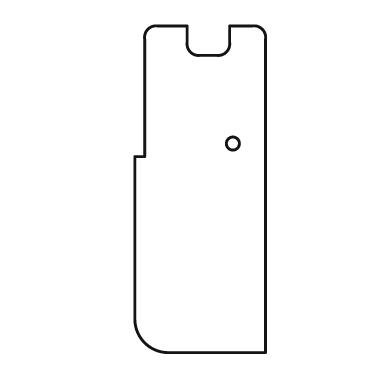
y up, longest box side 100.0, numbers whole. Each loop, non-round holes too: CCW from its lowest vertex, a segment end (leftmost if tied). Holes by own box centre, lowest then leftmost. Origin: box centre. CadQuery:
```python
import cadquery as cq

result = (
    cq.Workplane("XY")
    .moveTo(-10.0, -50.0)
    .lineTo(20.0, -50.0)
    .lineTo(20.0, 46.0)
    .threePointArc((19.0, 49.0), (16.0, 50.0))
    .lineTo(9.0, 50.0)
    .lineTo(9.0, 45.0)
    .threePointArc((8.0, 42.0), (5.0, 41.0))
    .lineTo(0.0, 41.0)
    .threePointArc((-3.0, 42.0), (-4.0, 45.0))
    .lineTo(-4.0, 50.0)
    .lineTo(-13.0, 50.0)
    .threePointArc((-16.0, 49.0), (-17.0, 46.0))
    .lineTo(-17.0, 10.0)
    .lineTo(-20.0, 10.0)
    .lineTo(-20.0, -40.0)
    .threePointArc((-17.0, -47.0), (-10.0, -50.0))
    .close()
    .moveTo(10.0, 14.0)
    .circle(2.0)
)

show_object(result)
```